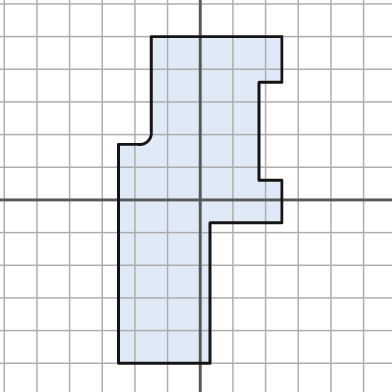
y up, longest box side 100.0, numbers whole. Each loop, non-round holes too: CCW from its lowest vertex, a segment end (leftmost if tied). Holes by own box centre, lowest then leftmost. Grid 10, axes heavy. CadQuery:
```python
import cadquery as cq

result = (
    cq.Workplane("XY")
    .moveTo(-25.0, -50.0)
    .lineTo(3.0, -50.0)
    .lineTo(3.0, -7.0)
    .lineTo(25.0, -7.0)
    .lineTo(25.0, 6.0)
    .lineTo(18.0, 6.0)
    .lineTo(18.0, 36.0)
    .lineTo(25.0, 36.0)
    .lineTo(25.0, 50.0)
    .lineTo(-15.0, 50.0)
    .lineTo(-15.0, 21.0)
    .threePointArc((-16.0, 18.0), (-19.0, 17.0))
    .lineTo(-25.0, 17.0)
    .close()
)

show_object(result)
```